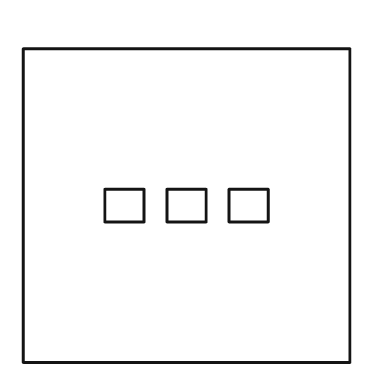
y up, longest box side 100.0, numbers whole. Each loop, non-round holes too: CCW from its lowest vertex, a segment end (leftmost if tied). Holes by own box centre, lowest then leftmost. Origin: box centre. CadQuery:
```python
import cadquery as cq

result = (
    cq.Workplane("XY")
    .moveTo(-50.0, -48.0)
    .lineTo(50.0, -48.0)
    .lineTo(50.0, 48.0)
    .lineTo(-50.0, 48.0)
    .close()
    .moveTo(-25.0, -5.0)
    .lineTo(-13.0, -5.0)
    .lineTo(-13.0, 5.0)
    .lineTo(-25.0, 5.0)
    .close()
    .moveTo(-6.0, -5.0)
    .lineTo(6.0, -5.0)
    .lineTo(6.0, 5.0)
    .lineTo(-6.0, 5.0)
    .close()
    .moveTo(13.0, -5.0)
    .lineTo(25.0, -5.0)
    .lineTo(25.0, 5.0)
    .lineTo(13.0, 5.0)
    .close()
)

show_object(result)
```